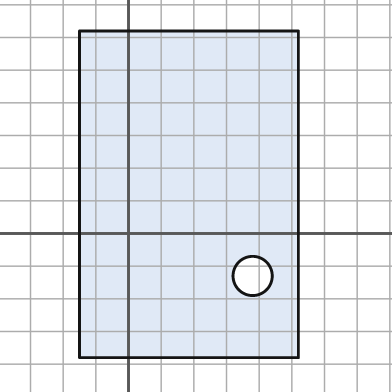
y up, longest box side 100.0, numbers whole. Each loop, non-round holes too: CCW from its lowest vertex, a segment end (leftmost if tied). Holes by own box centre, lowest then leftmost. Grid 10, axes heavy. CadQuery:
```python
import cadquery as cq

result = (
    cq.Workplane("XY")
    .moveTo(-15.0, -38.0)
    .lineTo(52.0, -38.0)
    .lineTo(52.0, 62.0)
    .lineTo(-15.0, 62.0)
    .close()
    .moveTo(38.0, -13.0)
    .circle(6.0)
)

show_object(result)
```